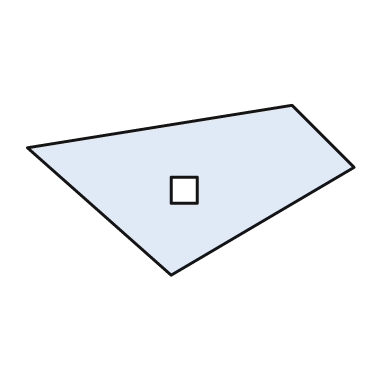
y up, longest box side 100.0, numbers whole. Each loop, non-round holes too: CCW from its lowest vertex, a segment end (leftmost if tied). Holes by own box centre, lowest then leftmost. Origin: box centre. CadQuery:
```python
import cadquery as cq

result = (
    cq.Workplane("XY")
    .moveTo(-6.0, -26.0)
    .lineTo(50.0, 7.0)
    .lineTo(31.0, 26.0)
    .lineTo(-50.0, 13.0)
    .close()
    .moveTo(-6.0, -4.0)
    .lineTo(2.0, -4.0)
    .lineTo(2.0, 4.0)
    .lineTo(-6.0, 4.0)
    .close()
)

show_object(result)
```